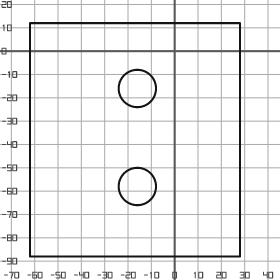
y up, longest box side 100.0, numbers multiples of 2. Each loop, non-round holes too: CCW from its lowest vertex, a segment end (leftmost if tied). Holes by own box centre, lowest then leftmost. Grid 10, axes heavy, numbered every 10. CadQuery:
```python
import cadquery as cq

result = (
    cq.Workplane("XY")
    .moveTo(-62.0, -88.0)
    .lineTo(28.0, -88.0)
    .lineTo(28.0, 12.0)
    .lineTo(-62.0, 12.0)
    .close()
    .moveTo(-16.0, -58.0)
    .circle(8.0)
    .moveTo(-16.0, -16.0)
    .circle(8.0)
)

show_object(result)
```